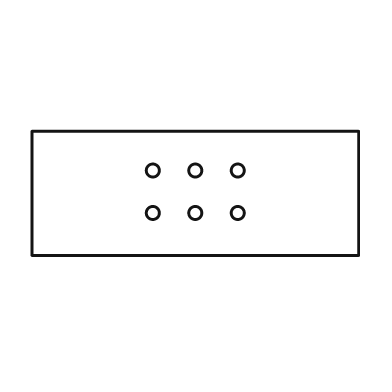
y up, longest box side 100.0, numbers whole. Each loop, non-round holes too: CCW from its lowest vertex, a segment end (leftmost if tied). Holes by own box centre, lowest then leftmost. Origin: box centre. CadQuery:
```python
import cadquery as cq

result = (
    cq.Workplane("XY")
    .moveTo(-50.0, -19.0)
    .lineTo(50.0, -19.0)
    .lineTo(50.0, 19.0)
    .lineTo(-50.0, 19.0)
    .close()
    .moveTo(-13.0, -6.0)
    .circle(2.0)
    .moveTo(0.0, -6.0)
    .circle(2.0)
    .moveTo(13.0, -6.0)
    .circle(2.0)
    .moveTo(-13.0, 7.0)
    .circle(2.0)
    .moveTo(0.0, 7.0)
    .circle(2.0)
    .moveTo(13.0, 7.0)
    .circle(2.0)
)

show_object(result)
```